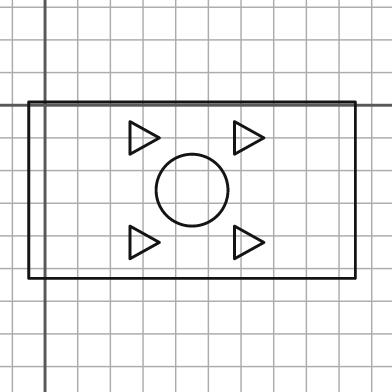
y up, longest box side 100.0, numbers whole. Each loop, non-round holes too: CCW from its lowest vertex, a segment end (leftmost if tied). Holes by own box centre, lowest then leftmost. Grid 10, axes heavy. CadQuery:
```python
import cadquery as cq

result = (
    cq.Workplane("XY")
    .moveTo(-5.0, -53.0)
    .lineTo(95.0, -53.0)
    .lineTo(95.0, 1.0)
    .lineTo(-5.0, 1.0)
    .close()
    .moveTo(26.0, -47.0)
    .lineTo(35.0, -42.0)
    .lineTo(26.0, -37.0)
    .close()
    .moveTo(58.0, -47.0)
    .lineTo(67.0, -42.0)
    .lineTo(58.0, -37.0)
    .close()
    .moveTo(45.0, -26.0)
    .circle(11.0)
    .moveTo(26.0, -15.0)
    .lineTo(35.0, -10.0)
    .lineTo(26.0, -5.0)
    .close()
    .moveTo(58.0, -15.0)
    .lineTo(67.0, -10.0)
    .lineTo(58.0, -5.0)
    .close()
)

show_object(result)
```